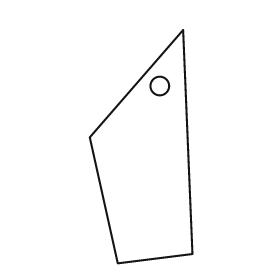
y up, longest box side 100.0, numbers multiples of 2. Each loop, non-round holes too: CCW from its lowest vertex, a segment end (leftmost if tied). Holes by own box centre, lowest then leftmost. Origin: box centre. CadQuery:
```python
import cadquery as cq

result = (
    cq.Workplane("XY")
    .moveTo(-10.0, -50.0)
    .lineTo(22.0, -46.0)
    .lineTo(18.0, 50.0)
    .lineTo(-22.0, 4.0)
    .close()
    .moveTo(8.0, 26.0)
    .circle(4.0)
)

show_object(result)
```